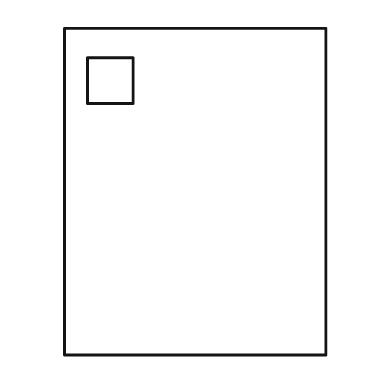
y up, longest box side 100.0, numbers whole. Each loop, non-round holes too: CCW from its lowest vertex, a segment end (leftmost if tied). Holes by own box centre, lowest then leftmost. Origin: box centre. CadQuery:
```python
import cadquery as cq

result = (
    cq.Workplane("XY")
    .moveTo(-40.0, -50.0)
    .lineTo(40.0, -50.0)
    .lineTo(40.0, 50.0)
    .lineTo(-40.0, 50.0)
    .close()
    .moveTo(-33.0, 27.0)
    .lineTo(-19.0, 27.0)
    .lineTo(-19.0, 41.0)
    .lineTo(-33.0, 41.0)
    .close()
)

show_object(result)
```